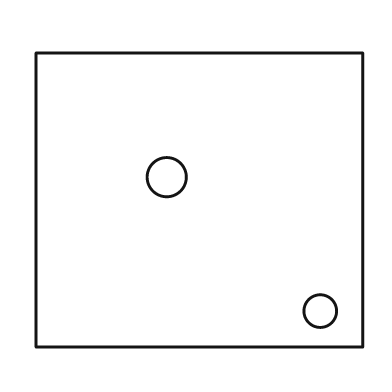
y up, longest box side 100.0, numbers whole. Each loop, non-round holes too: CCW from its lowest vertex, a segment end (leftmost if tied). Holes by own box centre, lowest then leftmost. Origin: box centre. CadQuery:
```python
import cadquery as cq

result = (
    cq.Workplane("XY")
    .moveTo(-50.0, -45.0)
    .lineTo(50.0, -45.0)
    .lineTo(50.0, 45.0)
    .lineTo(-50.0, 45.0)
    .close()
    .moveTo(37.0, -34.0)
    .circle(5.0)
    .moveTo(-10.0, 7.0)
    .circle(6.0)
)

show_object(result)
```